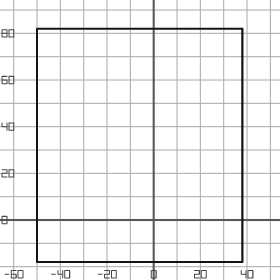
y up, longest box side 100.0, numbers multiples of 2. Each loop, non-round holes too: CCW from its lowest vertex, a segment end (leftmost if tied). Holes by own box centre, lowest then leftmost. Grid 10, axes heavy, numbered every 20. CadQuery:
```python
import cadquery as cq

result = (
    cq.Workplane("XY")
    .moveTo(-50.0, -18.0)
    .lineTo(38.0, -18.0)
    .lineTo(38.0, 82.0)
    .lineTo(-50.0, 82.0)
    .close()
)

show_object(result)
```